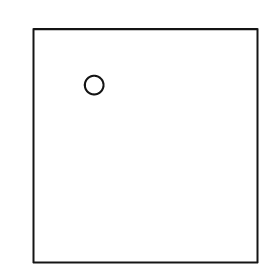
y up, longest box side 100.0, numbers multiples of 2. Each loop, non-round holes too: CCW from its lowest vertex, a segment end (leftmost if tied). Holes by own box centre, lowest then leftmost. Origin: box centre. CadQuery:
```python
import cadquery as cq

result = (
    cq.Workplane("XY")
    .moveTo(-48.0, -50.0)
    .lineTo(48.0, -50.0)
    .lineTo(48.0, 50.0)
    .lineTo(-48.0, 50.0)
    .close()
    .moveTo(-22.0, 26.0)
    .circle(4.0)
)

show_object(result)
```